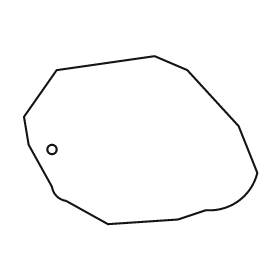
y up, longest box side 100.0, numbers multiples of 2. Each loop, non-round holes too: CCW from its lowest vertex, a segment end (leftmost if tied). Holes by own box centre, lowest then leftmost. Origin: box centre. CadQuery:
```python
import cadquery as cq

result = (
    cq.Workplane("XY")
    .moveTo(-14.0, -36.0)
    .lineTo(16.0, -34.0)
    .lineTo(28.0, -30.0)
    .threePointArc((42.0, -26.0), (50.0, -14.0))
    .lineTo(42.0, 6.0)
    .lineTo(20.0, 30.0)
    .lineTo(6.0, 36.0)
    .lineTo(-36.0, 30.0)
    .lineTo(-50.0, 10.0)
    .lineTo(-48.0, -2.0)
    .lineTo(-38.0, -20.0)
    .threePointArc((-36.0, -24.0), (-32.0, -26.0))
    .close()
    .moveTo(-38.0, -4.0)
    .circle(2.0)
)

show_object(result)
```